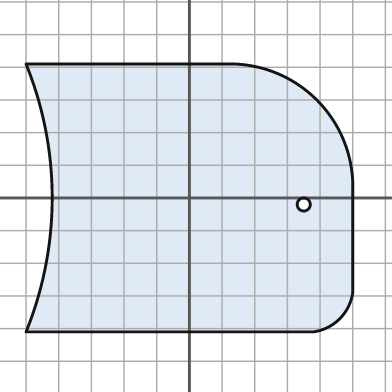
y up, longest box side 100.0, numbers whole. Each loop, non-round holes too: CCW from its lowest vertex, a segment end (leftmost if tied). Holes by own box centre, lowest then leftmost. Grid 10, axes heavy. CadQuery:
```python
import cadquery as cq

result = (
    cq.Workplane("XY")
    .moveTo(-50.0, -41.0)
    .lineTo(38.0, -41.0)
    .threePointArc((46.0, -37.0), (50.0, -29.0))
    .lineTo(50.0, 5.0)
    .threePointArc((39.0, 30.0), (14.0, 41.0))
    .lineTo(-50.0, 41.0)
    .threePointArc((-42.0, 0.0), (-50.0, -41.0))
    .close()
    .moveTo(35.0, -2.0)
    .circle(2.0)
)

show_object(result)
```